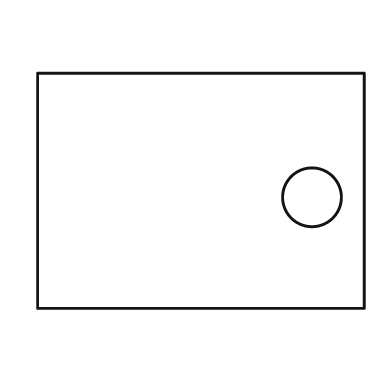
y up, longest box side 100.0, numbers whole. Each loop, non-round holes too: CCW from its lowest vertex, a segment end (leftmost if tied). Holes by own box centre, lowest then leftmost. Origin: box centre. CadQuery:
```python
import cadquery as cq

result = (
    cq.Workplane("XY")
    .moveTo(-50.0, -36.0)
    .lineTo(50.0, -36.0)
    .lineTo(50.0, 36.0)
    .lineTo(-50.0, 36.0)
    .close()
    .moveTo(34.0, -2.0)
    .circle(9.0)
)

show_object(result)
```